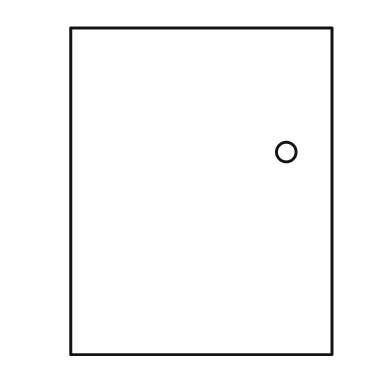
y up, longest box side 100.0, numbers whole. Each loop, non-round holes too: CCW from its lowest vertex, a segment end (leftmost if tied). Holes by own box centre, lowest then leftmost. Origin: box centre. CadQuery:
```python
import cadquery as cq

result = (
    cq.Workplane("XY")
    .moveTo(-40.0, -50.0)
    .lineTo(40.0, -50.0)
    .lineTo(40.0, 50.0)
    .lineTo(-40.0, 50.0)
    .close()
    .moveTo(26.0, 12.0)
    .circle(3.0)
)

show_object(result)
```